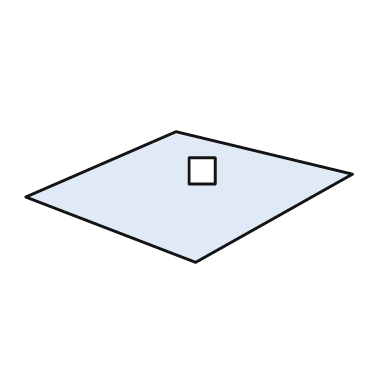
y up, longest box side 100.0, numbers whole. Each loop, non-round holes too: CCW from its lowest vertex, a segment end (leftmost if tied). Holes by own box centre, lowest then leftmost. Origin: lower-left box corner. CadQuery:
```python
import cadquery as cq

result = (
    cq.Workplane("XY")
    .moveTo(52.0, 0.0)
    .lineTo(100.0, 27.0)
    .lineTo(46.0, 40.0)
    .lineTo(0.0, 20.0)
    .close()
    .moveTo(50.0, 24.0)
    .lineTo(58.0, 24.0)
    .lineTo(58.0, 32.0)
    .lineTo(50.0, 32.0)
    .close()
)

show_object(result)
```